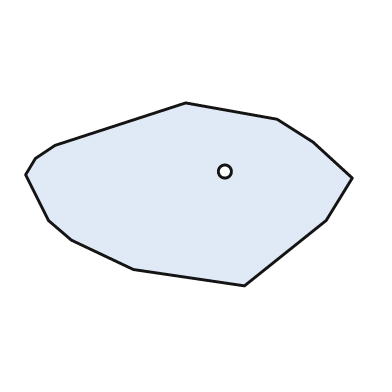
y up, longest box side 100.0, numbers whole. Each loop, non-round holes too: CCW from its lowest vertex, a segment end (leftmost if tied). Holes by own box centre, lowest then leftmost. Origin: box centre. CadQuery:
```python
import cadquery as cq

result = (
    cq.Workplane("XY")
    .moveTo(17.0, -28.0)
    .lineTo(42.0, -8.0)
    .lineTo(50.0, 5.0)
    .lineTo(38.0, 16.0)
    .lineTo(27.0, 23.0)
    .lineTo(-1.0, 28.0)
    .lineTo(-41.0, 15.0)
    .lineTo(-47.0, 11.0)
    .lineTo(-50.0, 6.0)
    .lineTo(-43.0, -8.0)
    .lineTo(-36.0, -14.0)
    .lineTo(-17.0, -23.0)
    .close()
    .moveTo(11.0, 7.0)
    .circle(2.0)
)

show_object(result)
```